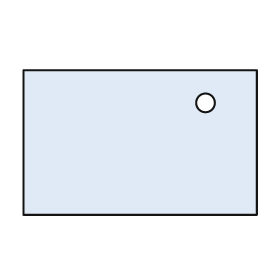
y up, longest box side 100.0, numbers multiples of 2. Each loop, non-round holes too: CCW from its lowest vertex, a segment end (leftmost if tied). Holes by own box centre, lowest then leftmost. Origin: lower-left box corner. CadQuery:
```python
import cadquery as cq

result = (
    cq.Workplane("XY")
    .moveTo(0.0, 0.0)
    .lineTo(100.0, 0.0)
    .lineTo(100.0, 62.0)
    .lineTo(0.0, 62.0)
    .close()
    .moveTo(78.0, 48.0)
    .circle(4.0)
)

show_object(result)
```